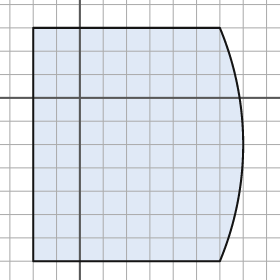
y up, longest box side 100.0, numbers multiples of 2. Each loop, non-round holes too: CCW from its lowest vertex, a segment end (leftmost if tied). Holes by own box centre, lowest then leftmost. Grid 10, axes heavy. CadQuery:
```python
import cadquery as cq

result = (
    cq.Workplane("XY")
    .moveTo(-20.0, -70.0)
    .lineTo(60.0, -70.0)
    .threePointArc((70.0, -20.0), (60.0, 30.0))
    .lineTo(-20.0, 30.0)
    .close()
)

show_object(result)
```